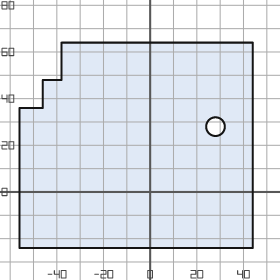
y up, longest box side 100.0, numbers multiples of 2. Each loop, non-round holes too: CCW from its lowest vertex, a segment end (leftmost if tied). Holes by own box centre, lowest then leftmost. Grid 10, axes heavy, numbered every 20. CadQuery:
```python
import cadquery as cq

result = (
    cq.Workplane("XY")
    .moveTo(-56.0, -24.0)
    .lineTo(44.0, -24.0)
    .lineTo(44.0, 64.0)
    .lineTo(-38.0, 64.0)
    .lineTo(-38.0, 48.0)
    .lineTo(-46.0, 48.0)
    .lineTo(-46.0, 36.0)
    .lineTo(-56.0, 36.0)
    .close()
    .moveTo(28.0, 28.0)
    .circle(4.0)
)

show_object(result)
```